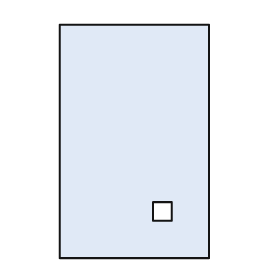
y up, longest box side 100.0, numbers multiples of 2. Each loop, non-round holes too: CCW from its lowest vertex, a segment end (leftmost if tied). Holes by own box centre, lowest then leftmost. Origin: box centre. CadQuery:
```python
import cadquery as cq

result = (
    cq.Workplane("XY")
    .moveTo(-32.0, -50.0)
    .lineTo(32.0, -50.0)
    .lineTo(32.0, 50.0)
    .lineTo(-32.0, 50.0)
    .close()
    .moveTo(8.0, -34.0)
    .lineTo(16.0, -34.0)
    .lineTo(16.0, -26.0)
    .lineTo(8.0, -26.0)
    .close()
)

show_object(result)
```